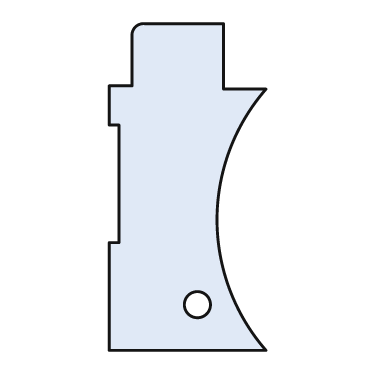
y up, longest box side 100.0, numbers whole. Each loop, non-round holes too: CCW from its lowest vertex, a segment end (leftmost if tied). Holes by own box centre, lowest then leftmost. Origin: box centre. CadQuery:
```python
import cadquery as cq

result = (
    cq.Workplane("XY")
    .moveTo(-24.0, -50.0)
    .lineTo(24.0, -50.0)
    .threePointArc((9.0, -10.0), (24.0, 30.0))
    .lineTo(11.0, 30.0)
    .lineTo(11.0, 50.0)
    .lineTo(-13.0, 50.0)
    .threePointArc((-16.0, 49.0), (-17.0, 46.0))
    .lineTo(-17.0, 31.0)
    .lineTo(-24.0, 31.0)
    .lineTo(-24.0, 19.0)
    .lineTo(-21.0, 19.0)
    .lineTo(-21.0, -17.0)
    .lineTo(-24.0, -17.0)
    .close()
    .moveTo(3.0, -36.0)
    .circle(4.0)
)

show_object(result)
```